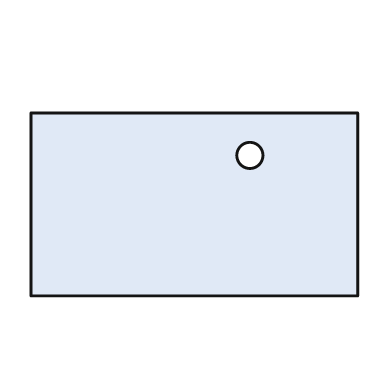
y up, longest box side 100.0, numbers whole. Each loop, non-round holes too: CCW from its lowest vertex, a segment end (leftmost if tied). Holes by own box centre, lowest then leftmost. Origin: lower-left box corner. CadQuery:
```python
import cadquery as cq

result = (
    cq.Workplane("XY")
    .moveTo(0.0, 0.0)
    .lineTo(100.0, 0.0)
    .lineTo(100.0, 56.0)
    .lineTo(0.0, 56.0)
    .close()
    .moveTo(67.0, 43.0)
    .circle(4.0)
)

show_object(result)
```